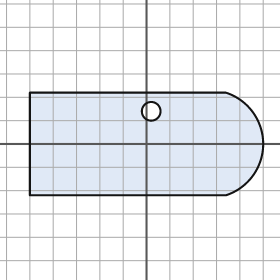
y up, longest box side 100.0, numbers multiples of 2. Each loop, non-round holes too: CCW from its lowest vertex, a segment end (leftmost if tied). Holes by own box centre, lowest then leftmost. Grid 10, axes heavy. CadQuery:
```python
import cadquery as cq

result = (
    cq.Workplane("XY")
    .moveTo(-50.0, -22.0)
    .lineTo(34.0, -22.0)
    .threePointArc((50.0, 0.0), (34.0, 22.0))
    .lineTo(-50.0, 22.0)
    .close()
    .moveTo(2.0, 14.0)
    .circle(4.0)
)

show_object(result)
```